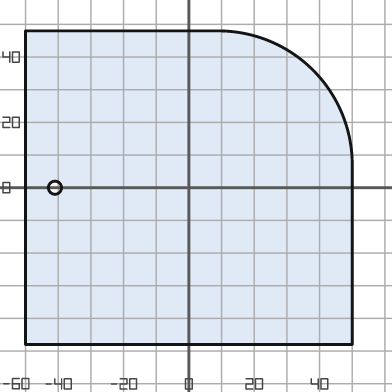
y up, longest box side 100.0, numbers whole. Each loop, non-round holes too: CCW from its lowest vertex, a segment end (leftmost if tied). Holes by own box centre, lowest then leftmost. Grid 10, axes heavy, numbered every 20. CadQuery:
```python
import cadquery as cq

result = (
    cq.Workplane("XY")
    .moveTo(-50.0, -48.0)
    .lineTo(50.0, -48.0)
    .lineTo(50.0, 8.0)
    .threePointArc((38.0, 36.0), (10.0, 48.0))
    .lineTo(-50.0, 48.0)
    .close()
    .moveTo(-41.0, 0.0)
    .circle(2.0)
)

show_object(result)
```